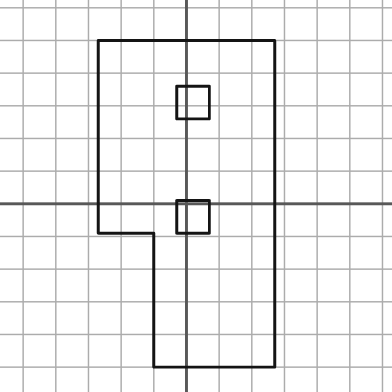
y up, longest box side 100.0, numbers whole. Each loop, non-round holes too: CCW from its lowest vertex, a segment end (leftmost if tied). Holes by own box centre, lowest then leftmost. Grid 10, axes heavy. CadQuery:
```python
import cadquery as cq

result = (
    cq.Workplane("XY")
    .moveTo(-10.0, -50.0)
    .lineTo(27.0, -50.0)
    .lineTo(27.0, 50.0)
    .lineTo(-27.0, 50.0)
    .lineTo(-27.0, -9.0)
    .lineTo(-10.0, -9.0)
    .close()
    .moveTo(-3.0, -9.0)
    .lineTo(7.0, -9.0)
    .lineTo(7.0, 1.0)
    .lineTo(-3.0, 1.0)
    .close()
    .moveTo(-3.0, 26.0)
    .lineTo(7.0, 26.0)
    .lineTo(7.0, 36.0)
    .lineTo(-3.0, 36.0)
    .close()
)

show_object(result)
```